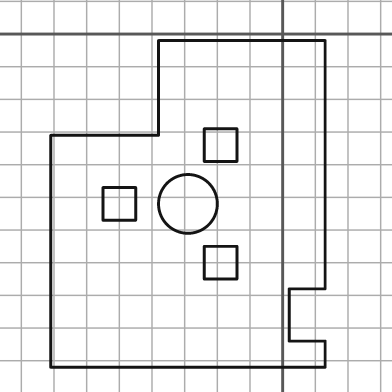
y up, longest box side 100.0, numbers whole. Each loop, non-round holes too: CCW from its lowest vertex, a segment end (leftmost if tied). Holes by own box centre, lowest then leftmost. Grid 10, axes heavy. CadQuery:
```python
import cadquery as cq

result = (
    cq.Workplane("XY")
    .moveTo(-71.0, -102.0)
    .lineTo(13.0, -102.0)
    .lineTo(13.0, -94.0)
    .lineTo(2.0, -94.0)
    .lineTo(2.0, -78.0)
    .lineTo(13.0, -78.0)
    .lineTo(13.0, -2.0)
    .lineTo(-38.0, -2.0)
    .lineTo(-38.0, -31.0)
    .lineTo(-71.0, -31.0)
    .close()
    .moveTo(-24.0, -75.0)
    .lineTo(-14.0, -75.0)
    .lineTo(-14.0, -65.0)
    .lineTo(-24.0, -65.0)
    .close()
    .moveTo(-55.0, -57.0)
    .lineTo(-45.0, -57.0)
    .lineTo(-45.0, -47.0)
    .lineTo(-55.0, -47.0)
    .close()
    .moveTo(-29.0, -52.0)
    .circle(9.0)
    .moveTo(-24.0, -39.0)
    .lineTo(-14.0, -39.0)
    .lineTo(-14.0, -29.0)
    .lineTo(-24.0, -29.0)
    .close()
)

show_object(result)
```